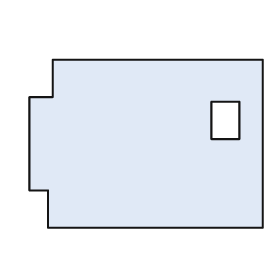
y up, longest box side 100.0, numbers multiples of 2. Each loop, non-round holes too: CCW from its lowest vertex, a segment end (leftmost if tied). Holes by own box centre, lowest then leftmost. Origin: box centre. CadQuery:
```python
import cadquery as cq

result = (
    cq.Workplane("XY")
    .moveTo(-42.0, -36.0)
    .lineTo(50.0, -36.0)
    .lineTo(50.0, 36.0)
    .lineTo(-40.0, 36.0)
    .lineTo(-40.0, 20.0)
    .lineTo(-50.0, 20.0)
    .lineTo(-50.0, -20.0)
    .lineTo(-42.0, -20.0)
    .close()
    .moveTo(28.0, 2.0)
    .lineTo(40.0, 2.0)
    .lineTo(40.0, 18.0)
    .lineTo(28.0, 18.0)
    .close()
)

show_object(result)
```